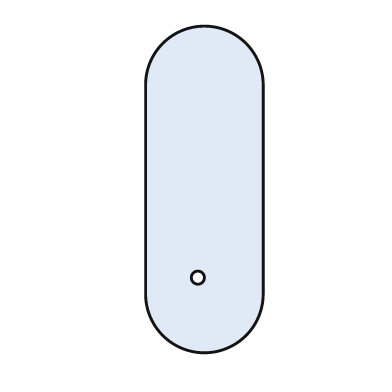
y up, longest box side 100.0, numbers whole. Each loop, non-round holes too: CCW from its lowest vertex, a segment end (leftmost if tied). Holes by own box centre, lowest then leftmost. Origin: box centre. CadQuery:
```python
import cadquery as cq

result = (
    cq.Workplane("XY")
    .moveTo(-18.0, -32.0)
    .threePointArc((0.0, -50.0), (18.0, -32.0))
    .lineTo(18.0, 32.0)
    .threePointArc((0.0, 50.0), (-18.0, 32.0))
    .close()
    .moveTo(-2.0, -27.0)
    .circle(2.0)
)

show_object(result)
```